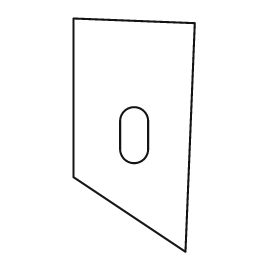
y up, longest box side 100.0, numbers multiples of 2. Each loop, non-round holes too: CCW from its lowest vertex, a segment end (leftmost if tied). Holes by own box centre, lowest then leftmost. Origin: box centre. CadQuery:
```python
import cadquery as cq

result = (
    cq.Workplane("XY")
    .moveTo(22.0, -50.0)
    .lineTo(26.0, 48.0)
    .lineTo(-26.0, 50.0)
    .lineTo(-26.0, -18.0)
    .close()
    .moveTo(-6.0, -6.0)
    .threePointArc((0.0, -12.0), (6.0, -6.0))
    .lineTo(6.0, 6.0)
    .threePointArc((0.0, 12.0), (-6.0, 6.0))
    .close()
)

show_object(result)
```